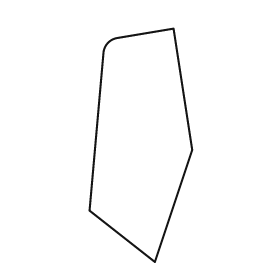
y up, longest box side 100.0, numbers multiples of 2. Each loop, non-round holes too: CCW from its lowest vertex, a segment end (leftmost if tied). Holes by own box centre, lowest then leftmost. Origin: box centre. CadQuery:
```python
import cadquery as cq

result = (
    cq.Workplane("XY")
    .moveTo(6.0, -50.0)
    .lineTo(22.0, -2.0)
    .lineTo(14.0, 50.0)
    .lineTo(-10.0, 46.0)
    .threePointArc((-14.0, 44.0), (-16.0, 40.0))
    .lineTo(-22.0, -28.0)
    .close()
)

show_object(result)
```